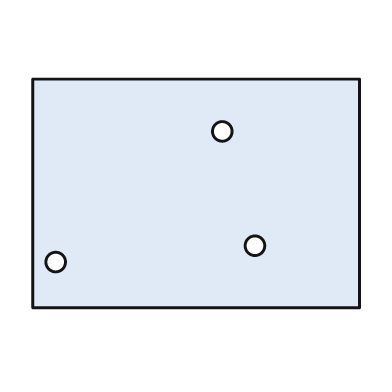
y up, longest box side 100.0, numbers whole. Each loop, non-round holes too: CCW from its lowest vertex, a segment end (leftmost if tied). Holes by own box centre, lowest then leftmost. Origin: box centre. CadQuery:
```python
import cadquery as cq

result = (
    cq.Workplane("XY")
    .moveTo(-50.0, -35.0)
    .lineTo(50.0, -35.0)
    .lineTo(50.0, 35.0)
    .lineTo(-50.0, 35.0)
    .close()
    .moveTo(-43.0, -21.0)
    .circle(3.0)
    .moveTo(18.0, -16.0)
    .circle(3.0)
    .moveTo(8.0, 19.0)
    .circle(3.0)
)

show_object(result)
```